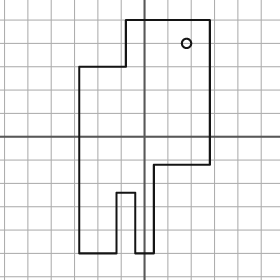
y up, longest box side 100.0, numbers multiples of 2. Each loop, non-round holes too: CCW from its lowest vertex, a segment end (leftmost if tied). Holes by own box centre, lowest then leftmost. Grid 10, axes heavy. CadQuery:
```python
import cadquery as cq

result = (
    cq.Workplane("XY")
    .moveTo(-28.0, -50.0)
    .lineTo(-12.0, -50.0)
    .lineTo(-12.0, -24.0)
    .lineTo(-4.0, -24.0)
    .lineTo(-4.0, -50.0)
    .lineTo(4.0, -50.0)
    .lineTo(4.0, -12.0)
    .lineTo(28.0, -12.0)
    .lineTo(28.0, 50.0)
    .lineTo(-8.0, 50.0)
    .lineTo(-8.0, 30.0)
    .lineTo(-28.0, 30.0)
    .close()
    .moveTo(18.0, 40.0)
    .circle(2.0)
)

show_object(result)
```